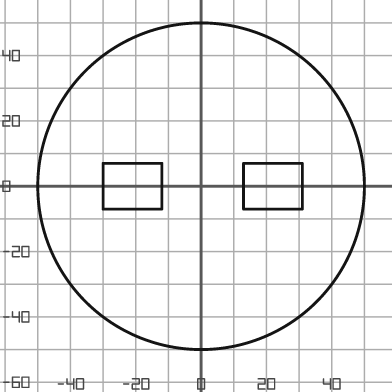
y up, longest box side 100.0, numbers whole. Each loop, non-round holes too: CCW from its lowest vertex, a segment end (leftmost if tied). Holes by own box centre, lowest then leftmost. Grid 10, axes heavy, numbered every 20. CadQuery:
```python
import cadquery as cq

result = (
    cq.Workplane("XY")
    .moveTo(0.0, 0.0)
    .circle(50.0)
    .moveTo(-30.0, -7.0)
    .lineTo(-12.0, -7.0)
    .lineTo(-12.0, 7.0)
    .lineTo(-30.0, 7.0)
    .close()
    .moveTo(13.0, -7.0)
    .lineTo(31.0, -7.0)
    .lineTo(31.0, 7.0)
    .lineTo(13.0, 7.0)
    .close()
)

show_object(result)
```